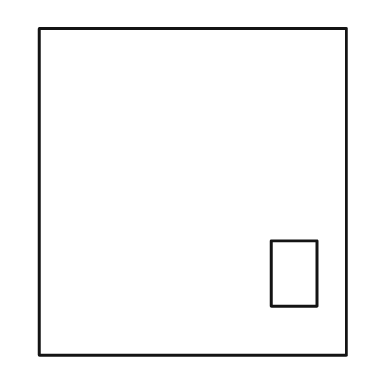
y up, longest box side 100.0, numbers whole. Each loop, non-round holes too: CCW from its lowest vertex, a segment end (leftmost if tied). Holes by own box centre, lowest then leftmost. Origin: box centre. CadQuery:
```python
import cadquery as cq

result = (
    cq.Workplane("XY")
    .moveTo(-47.0, -50.0)
    .lineTo(47.0, -50.0)
    .lineTo(47.0, 50.0)
    .lineTo(-47.0, 50.0)
    .close()
    .moveTo(24.0, -35.0)
    .lineTo(38.0, -35.0)
    .lineTo(38.0, -15.0)
    .lineTo(24.0, -15.0)
    .close()
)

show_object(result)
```